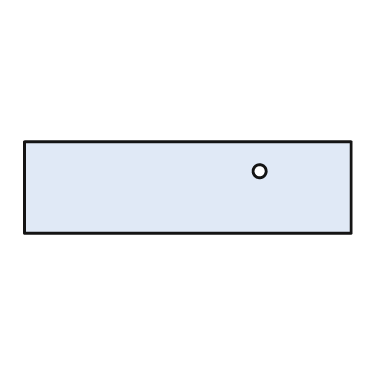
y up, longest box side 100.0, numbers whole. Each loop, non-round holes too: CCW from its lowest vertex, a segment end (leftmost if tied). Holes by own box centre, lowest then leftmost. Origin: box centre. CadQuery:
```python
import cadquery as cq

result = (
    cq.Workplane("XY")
    .moveTo(-50.0, -14.0)
    .lineTo(50.0, -14.0)
    .lineTo(50.0, 14.0)
    .lineTo(-50.0, 14.0)
    .close()
    .moveTo(22.0, 5.0)
    .circle(2.0)
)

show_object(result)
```